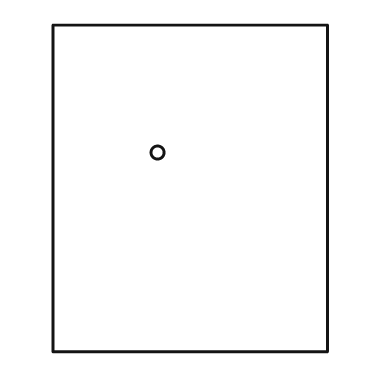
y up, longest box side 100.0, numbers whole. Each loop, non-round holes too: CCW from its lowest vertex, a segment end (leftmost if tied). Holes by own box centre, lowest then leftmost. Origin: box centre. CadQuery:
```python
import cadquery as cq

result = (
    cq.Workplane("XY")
    .moveTo(-42.0, -50.0)
    .lineTo(42.0, -50.0)
    .lineTo(42.0, 50.0)
    .lineTo(-42.0, 50.0)
    .close()
    .moveTo(-10.0, 11.0)
    .circle(2.0)
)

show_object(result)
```